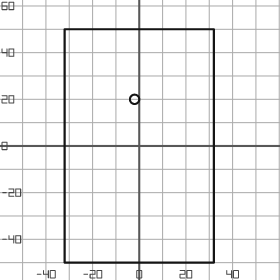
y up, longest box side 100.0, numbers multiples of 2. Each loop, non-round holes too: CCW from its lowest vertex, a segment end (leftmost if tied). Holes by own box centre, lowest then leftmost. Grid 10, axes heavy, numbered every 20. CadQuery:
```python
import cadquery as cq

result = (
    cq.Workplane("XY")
    .moveTo(-32.0, -50.0)
    .lineTo(32.0, -50.0)
    .lineTo(32.0, 50.0)
    .lineTo(-32.0, 50.0)
    .close()
    .moveTo(-2.0, 20.0)
    .circle(2.0)
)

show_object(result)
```